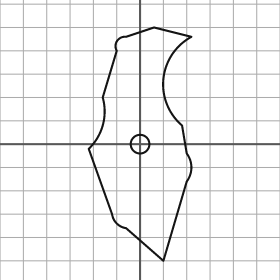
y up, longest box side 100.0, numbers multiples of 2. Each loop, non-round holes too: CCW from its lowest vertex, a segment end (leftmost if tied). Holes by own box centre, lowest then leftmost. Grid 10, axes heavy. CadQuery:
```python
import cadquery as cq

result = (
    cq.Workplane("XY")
    .moveTo(10.0, -50.0)
    .lineTo(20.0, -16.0)
    .threePointArc((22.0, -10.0), (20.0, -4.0))
    .lineTo(18.0, 8.0)
    .threePointArc((10.0, 28.0), (22.0, 46.0))
    .lineTo(6.0, 50.0)
    .lineTo(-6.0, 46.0)
    .threePointArc((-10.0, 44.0), (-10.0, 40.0))
    .lineTo(-16.0, 20.0)
    .threePointArc((-16.0, 8.0), (-22.0, -2.0))
    .lineTo(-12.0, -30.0)
    .threePointArc((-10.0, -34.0), (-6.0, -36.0))
    .close()
    .moveTo(0.0, 0.0)
    .circle(4.0)
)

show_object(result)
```